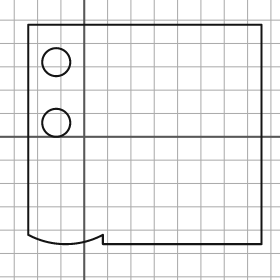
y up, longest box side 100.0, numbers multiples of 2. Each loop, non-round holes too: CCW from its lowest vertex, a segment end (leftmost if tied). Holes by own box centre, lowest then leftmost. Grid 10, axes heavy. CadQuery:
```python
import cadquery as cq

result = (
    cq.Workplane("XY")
    .moveTo(8.0, -46.0)
    .lineTo(76.0, -46.0)
    .lineTo(76.0, 48.0)
    .lineTo(-24.0, 48.0)
    .lineTo(-24.0, -42.0)
    .threePointArc((-8.0, -46.0), (8.0, -42.0))
    .close()
    .moveTo(-12.0, 6.0)
    .circle(6.0)
    .moveTo(-12.0, 32.0)
    .circle(6.0)
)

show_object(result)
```